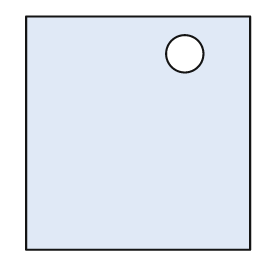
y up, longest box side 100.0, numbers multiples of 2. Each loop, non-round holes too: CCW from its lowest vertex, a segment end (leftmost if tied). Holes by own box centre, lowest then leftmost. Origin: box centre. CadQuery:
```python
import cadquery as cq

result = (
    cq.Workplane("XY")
    .moveTo(-48.0, -50.0)
    .lineTo(48.0, -50.0)
    .lineTo(48.0, 50.0)
    .lineTo(-48.0, 50.0)
    .close()
    .moveTo(20.0, 34.0)
    .circle(8.0)
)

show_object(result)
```